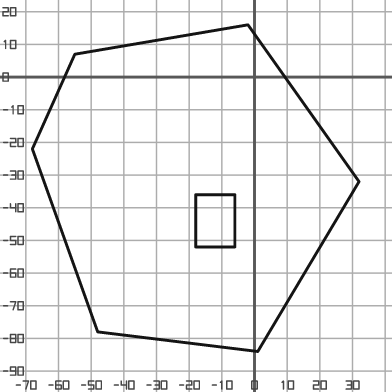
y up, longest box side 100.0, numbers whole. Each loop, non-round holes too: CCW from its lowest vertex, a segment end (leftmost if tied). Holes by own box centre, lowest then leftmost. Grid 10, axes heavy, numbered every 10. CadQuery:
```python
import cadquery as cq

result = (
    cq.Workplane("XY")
    .moveTo(1.0, -84.0)
    .lineTo(32.0, -32.0)
    .lineTo(-2.0, 16.0)
    .lineTo(-55.0, 7.0)
    .lineTo(-68.0, -22.0)
    .lineTo(-48.0, -78.0)
    .close()
    .moveTo(-18.0, -52.0)
    .lineTo(-6.0, -52.0)
    .lineTo(-6.0, -36.0)
    .lineTo(-18.0, -36.0)
    .close()
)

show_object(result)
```